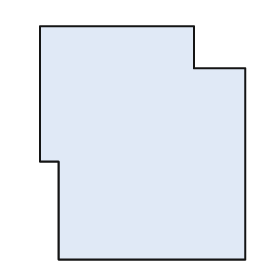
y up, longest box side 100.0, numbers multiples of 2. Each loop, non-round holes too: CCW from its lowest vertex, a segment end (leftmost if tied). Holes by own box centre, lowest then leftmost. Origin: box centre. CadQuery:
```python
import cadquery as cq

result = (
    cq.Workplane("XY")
    .moveTo(-36.0, -50.0)
    .lineTo(44.0, -50.0)
    .lineTo(44.0, 32.0)
    .lineTo(22.0, 32.0)
    .lineTo(22.0, 50.0)
    .lineTo(-44.0, 50.0)
    .lineTo(-44.0, -8.0)
    .lineTo(-36.0, -8.0)
    .close()
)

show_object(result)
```